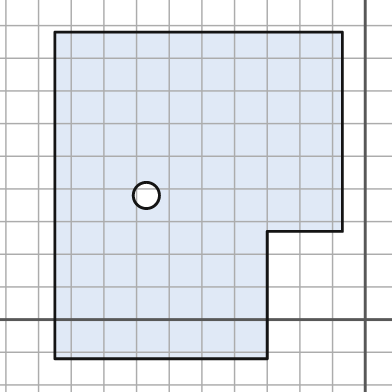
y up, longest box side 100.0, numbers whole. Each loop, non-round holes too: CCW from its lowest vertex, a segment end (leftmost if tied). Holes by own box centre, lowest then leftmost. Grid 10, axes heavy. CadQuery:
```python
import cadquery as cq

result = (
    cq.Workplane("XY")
    .moveTo(-95.0, -12.0)
    .lineTo(-30.0, -12.0)
    .lineTo(-30.0, 27.0)
    .lineTo(-7.0, 27.0)
    .lineTo(-7.0, 88.0)
    .lineTo(-95.0, 88.0)
    .close()
    .moveTo(-67.0, 38.0)
    .circle(4.0)
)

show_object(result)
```